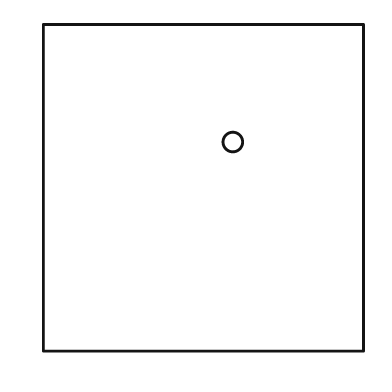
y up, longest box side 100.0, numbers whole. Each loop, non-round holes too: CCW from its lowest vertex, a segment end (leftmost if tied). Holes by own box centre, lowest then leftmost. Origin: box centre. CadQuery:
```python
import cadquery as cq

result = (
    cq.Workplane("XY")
    .moveTo(-49.0, -50.0)
    .lineTo(49.0, -50.0)
    .lineTo(49.0, 50.0)
    .lineTo(-49.0, 50.0)
    .close()
    .moveTo(9.0, 14.0)
    .circle(3.0)
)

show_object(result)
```